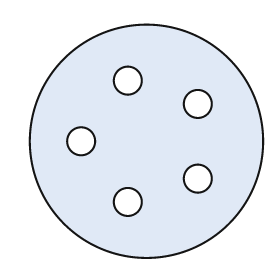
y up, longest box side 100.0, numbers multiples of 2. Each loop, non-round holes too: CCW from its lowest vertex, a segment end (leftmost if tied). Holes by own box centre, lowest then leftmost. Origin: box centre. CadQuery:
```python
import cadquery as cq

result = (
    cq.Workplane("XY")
    .moveTo(0.0, 0.0)
    .circle(50.0)
    .moveTo(-8.0, -26.0)
    .circle(6.0)
    .moveTo(22.0, -16.0)
    .circle(6.0)
    .moveTo(-28.0, 0.0)
    .circle(6.0)
    .moveTo(22.0, 16.0)
    .circle(6.0)
    .moveTo(-8.0, 26.0)
    .circle(6.0)
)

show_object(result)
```